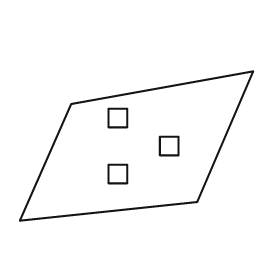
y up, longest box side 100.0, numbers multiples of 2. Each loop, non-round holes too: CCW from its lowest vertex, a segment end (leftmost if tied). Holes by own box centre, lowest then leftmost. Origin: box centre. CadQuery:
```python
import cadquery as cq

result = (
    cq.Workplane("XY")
    .moveTo(-50.0, -32.0)
    .lineTo(26.0, -24.0)
    .lineTo(50.0, 32.0)
    .lineTo(-28.0, 18.0)
    .close()
    .moveTo(-12.0, -16.0)
    .lineTo(-4.0, -16.0)
    .lineTo(-4.0, -8.0)
    .lineTo(-12.0, -8.0)
    .close()
    .moveTo(10.0, -4.0)
    .lineTo(18.0, -4.0)
    .lineTo(18.0, 4.0)
    .lineTo(10.0, 4.0)
    .close()
    .moveTo(-12.0, 8.0)
    .lineTo(-4.0, 8.0)
    .lineTo(-4.0, 16.0)
    .lineTo(-12.0, 16.0)
    .close()
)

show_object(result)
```